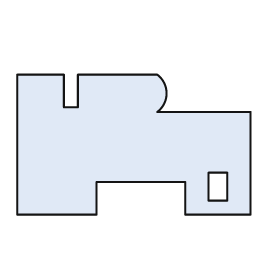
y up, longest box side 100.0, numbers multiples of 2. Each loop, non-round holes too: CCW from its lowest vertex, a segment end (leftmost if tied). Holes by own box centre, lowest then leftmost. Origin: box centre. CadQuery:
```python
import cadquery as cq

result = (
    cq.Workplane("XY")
    .moveTo(-50.0, -30.0)
    .lineTo(-16.0, -30.0)
    .lineTo(-16.0, -16.0)
    .lineTo(22.0, -16.0)
    .lineTo(22.0, -30.0)
    .lineTo(50.0, -30.0)
    .lineTo(50.0, 14.0)
    .lineTo(10.0, 14.0)
    .threePointArc((14.0, 22.0), (10.0, 30.0))
    .lineTo(-24.0, 30.0)
    .lineTo(-24.0, 16.0)
    .lineTo(-30.0, 16.0)
    .lineTo(-30.0, 30.0)
    .lineTo(-50.0, 30.0)
    .close()
    .moveTo(32.0, -24.0)
    .lineTo(40.0, -24.0)
    .lineTo(40.0, -12.0)
    .lineTo(32.0, -12.0)
    .close()
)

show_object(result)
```